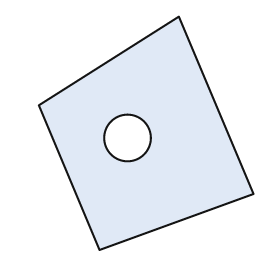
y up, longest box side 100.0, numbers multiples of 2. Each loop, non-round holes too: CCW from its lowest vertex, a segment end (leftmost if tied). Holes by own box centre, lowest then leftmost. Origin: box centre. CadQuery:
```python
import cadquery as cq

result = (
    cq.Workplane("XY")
    .moveTo(-20.0, -50.0)
    .lineTo(46.0, -26.0)
    .lineTo(14.0, 50.0)
    .lineTo(-46.0, 12.0)
    .close()
    .moveTo(-8.0, -2.0)
    .circle(10.0)
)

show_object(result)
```